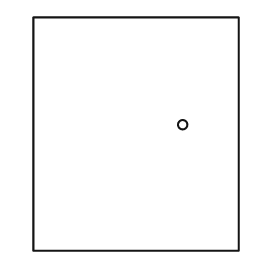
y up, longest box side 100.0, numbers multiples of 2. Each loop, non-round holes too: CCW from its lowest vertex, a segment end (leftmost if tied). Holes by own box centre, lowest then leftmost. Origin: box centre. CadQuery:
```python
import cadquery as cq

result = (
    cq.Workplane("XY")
    .moveTo(-44.0, -50.0)
    .lineTo(44.0, -50.0)
    .lineTo(44.0, 50.0)
    .lineTo(-44.0, 50.0)
    .close()
    .moveTo(20.0, 4.0)
    .circle(2.0)
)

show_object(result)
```